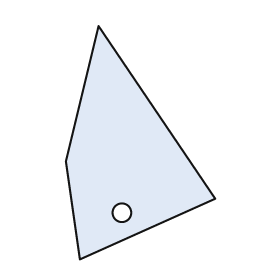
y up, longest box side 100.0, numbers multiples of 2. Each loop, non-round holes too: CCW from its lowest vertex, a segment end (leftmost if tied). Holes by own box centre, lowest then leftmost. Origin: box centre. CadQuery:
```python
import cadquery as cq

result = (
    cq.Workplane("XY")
    .moveTo(-26.0, -50.0)
    .lineTo(32.0, -24.0)
    .lineTo(-18.0, 50.0)
    .lineTo(-32.0, -8.0)
    .close()
    .moveTo(-8.0, -30.0)
    .circle(4.0)
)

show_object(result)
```